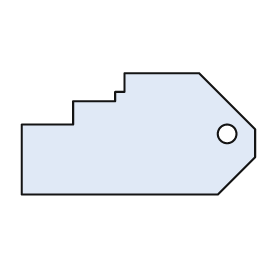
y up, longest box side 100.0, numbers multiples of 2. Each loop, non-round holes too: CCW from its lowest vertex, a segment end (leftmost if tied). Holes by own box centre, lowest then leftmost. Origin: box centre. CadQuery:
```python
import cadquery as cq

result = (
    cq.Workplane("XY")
    .moveTo(-50.0, -26.0)
    .lineTo(34.0, -26.0)
    .lineTo(50.0, -10.0)
    .lineTo(50.0, 2.0)
    .lineTo(26.0, 26.0)
    .lineTo(-6.0, 26.0)
    .lineTo(-6.0, 18.0)
    .lineTo(-10.0, 18.0)
    .lineTo(-10.0, 14.0)
    .lineTo(-28.0, 14.0)
    .lineTo(-28.0, 4.0)
    .lineTo(-50.0, 4.0)
    .close()
    .moveTo(38.0, 0.0)
    .circle(4.0)
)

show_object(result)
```